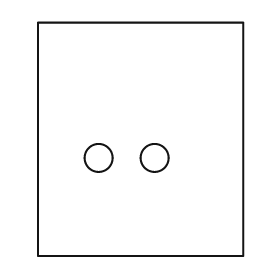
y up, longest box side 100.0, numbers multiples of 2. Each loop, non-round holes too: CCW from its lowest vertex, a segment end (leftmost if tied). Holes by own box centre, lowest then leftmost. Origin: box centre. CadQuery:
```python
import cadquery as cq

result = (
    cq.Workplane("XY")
    .moveTo(-44.0, -50.0)
    .lineTo(44.0, -50.0)
    .lineTo(44.0, 50.0)
    .lineTo(-44.0, 50.0)
    .close()
    .moveTo(-18.0, -8.0)
    .circle(6.0)
    .moveTo(6.0, -8.0)
    .circle(6.0)
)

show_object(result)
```